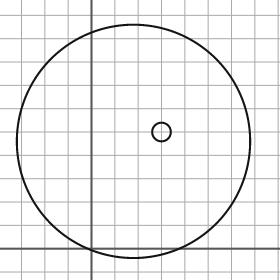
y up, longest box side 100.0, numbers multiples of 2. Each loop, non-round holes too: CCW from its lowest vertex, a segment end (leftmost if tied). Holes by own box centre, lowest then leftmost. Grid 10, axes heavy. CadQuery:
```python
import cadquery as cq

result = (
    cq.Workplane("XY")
    .moveTo(18.0, 46.0)
    .circle(50.0)
    .moveTo(30.0, 50.0)
    .circle(4.0)
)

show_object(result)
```